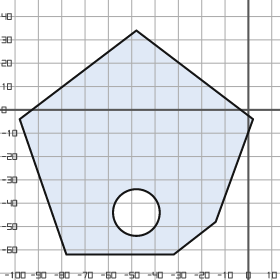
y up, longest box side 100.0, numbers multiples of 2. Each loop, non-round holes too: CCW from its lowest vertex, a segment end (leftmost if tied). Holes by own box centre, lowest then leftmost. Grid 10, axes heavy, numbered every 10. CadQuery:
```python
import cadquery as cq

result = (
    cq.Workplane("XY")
    .moveTo(-78.0, -62.0)
    .lineTo(-32.0, -62.0)
    .lineTo(-14.0, -48.0)
    .lineTo(2.0, -4.0)
    .lineTo(-48.0, 34.0)
    .lineTo(-98.0, -4.0)
    .close()
    .moveTo(-48.0, -44.0)
    .circle(10.0)
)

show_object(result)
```